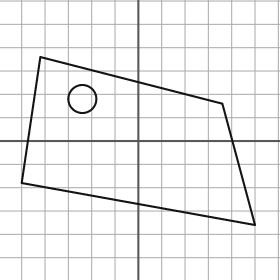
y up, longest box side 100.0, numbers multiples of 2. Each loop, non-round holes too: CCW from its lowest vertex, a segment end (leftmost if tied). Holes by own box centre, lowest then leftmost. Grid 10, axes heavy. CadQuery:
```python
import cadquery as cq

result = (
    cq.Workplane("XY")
    .moveTo(50.0, -36.0)
    .lineTo(36.0, 16.0)
    .lineTo(-42.0, 36.0)
    .lineTo(-50.0, -18.0)
    .close()
    .moveTo(-24.0, 18.0)
    .circle(6.0)
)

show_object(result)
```